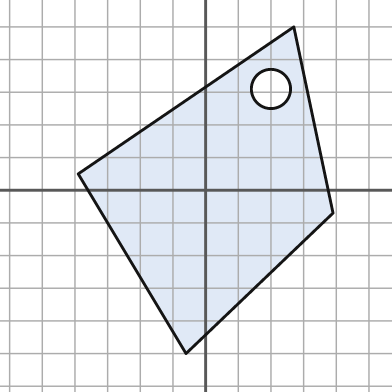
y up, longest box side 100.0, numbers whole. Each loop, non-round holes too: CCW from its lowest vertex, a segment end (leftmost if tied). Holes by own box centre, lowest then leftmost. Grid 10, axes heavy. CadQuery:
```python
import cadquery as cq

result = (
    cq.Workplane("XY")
    .moveTo(-6.0, -50.0)
    .lineTo(39.0, -7.0)
    .lineTo(27.0, 50.0)
    .lineTo(-39.0, 5.0)
    .close()
    .moveTo(20.0, 31.0)
    .circle(6.0)
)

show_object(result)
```